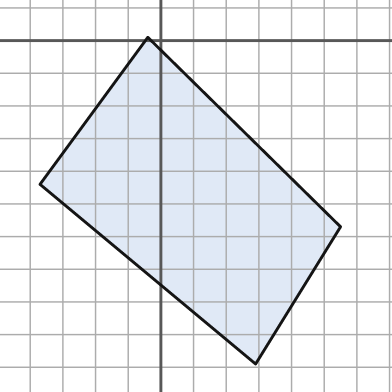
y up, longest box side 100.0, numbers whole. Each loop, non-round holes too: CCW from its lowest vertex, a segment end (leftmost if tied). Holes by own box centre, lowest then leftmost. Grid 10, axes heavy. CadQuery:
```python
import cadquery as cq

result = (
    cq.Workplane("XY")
    .moveTo(29.0, -99.0)
    .lineTo(55.0, -57.0)
    .lineTo(-4.0, 1.0)
    .lineTo(-37.0, -44.0)
    .close()
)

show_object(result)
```